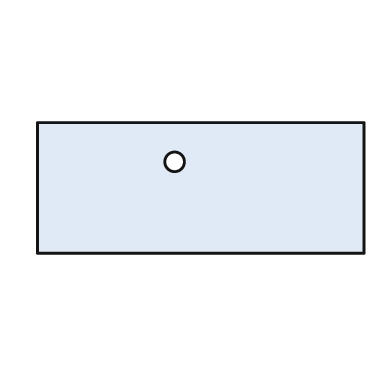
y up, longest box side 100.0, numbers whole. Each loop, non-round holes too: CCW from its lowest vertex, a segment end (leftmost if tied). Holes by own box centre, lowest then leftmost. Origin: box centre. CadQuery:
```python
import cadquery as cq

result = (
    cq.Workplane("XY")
    .moveTo(-50.0, -20.0)
    .lineTo(50.0, -20.0)
    .lineTo(50.0, 20.0)
    .lineTo(-50.0, 20.0)
    .close()
    .moveTo(-8.0, 8.0)
    .circle(3.0)
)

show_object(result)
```